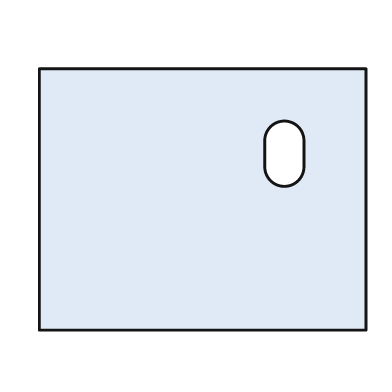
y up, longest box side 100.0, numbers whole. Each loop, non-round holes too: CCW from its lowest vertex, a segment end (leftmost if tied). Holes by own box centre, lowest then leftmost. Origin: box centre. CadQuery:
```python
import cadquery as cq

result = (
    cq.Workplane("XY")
    .moveTo(-50.0, -40.0)
    .lineTo(50.0, -40.0)
    .lineTo(50.0, 40.0)
    .lineTo(-50.0, 40.0)
    .close()
    .moveTo(19.0, 10.0)
    .threePointArc((25.0, 4.0), (31.0, 10.0))
    .lineTo(31.0, 18.0)
    .threePointArc((25.0, 24.0), (19.0, 18.0))
    .close()
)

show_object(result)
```